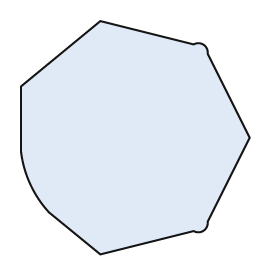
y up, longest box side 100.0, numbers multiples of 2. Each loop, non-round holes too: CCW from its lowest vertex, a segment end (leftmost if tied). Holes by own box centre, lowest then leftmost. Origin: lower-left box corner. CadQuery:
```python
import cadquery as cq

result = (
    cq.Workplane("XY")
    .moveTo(34.0, 0.0)
    .lineTo(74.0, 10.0)
    .threePointArc((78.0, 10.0), (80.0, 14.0))
    .lineTo(98.0, 50.0)
    .lineTo(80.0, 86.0)
    .threePointArc((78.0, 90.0), (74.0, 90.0))
    .lineTo(34.0, 100.0)
    .lineTo(0.0, 72.0)
    .lineTo(0.0, 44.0)
    .threePointArc((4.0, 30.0), (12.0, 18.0))
    .close()
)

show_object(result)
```